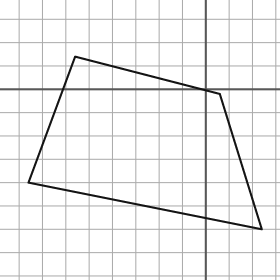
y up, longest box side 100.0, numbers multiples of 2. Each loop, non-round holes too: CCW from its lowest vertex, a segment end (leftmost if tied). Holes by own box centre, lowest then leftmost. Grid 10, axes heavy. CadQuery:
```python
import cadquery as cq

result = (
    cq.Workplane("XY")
    .moveTo(24.0, -60.0)
    .lineTo(6.0, -2.0)
    .lineTo(-56.0, 14.0)
    .lineTo(-76.0, -40.0)
    .close()
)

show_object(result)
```